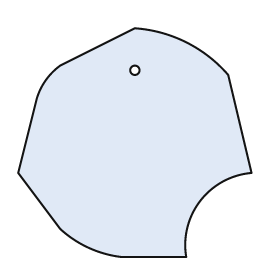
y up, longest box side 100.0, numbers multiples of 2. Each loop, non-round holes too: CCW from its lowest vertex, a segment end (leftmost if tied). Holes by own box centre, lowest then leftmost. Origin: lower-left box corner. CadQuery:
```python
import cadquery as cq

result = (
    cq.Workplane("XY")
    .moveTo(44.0, 0.0)
    .lineTo(72.0, 0.0)
    .threePointArc((78.0, 24.0), (100.0, 36.0))
    .lineTo(90.0, 78.0)
    .threePointArc((72.0, 92.0), (50.0, 98.0))
    .lineTo(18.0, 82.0)
    .threePointArc((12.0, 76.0), (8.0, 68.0))
    .lineTo(0.0, 36.0)
    .lineTo(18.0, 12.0)
    .threePointArc((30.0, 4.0), (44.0, 0.0))
    .close()
    .moveTo(50.0, 80.0)
    .circle(2.0)
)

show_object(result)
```